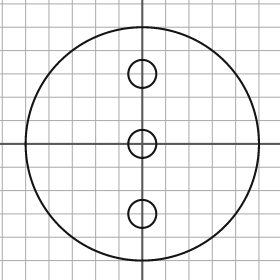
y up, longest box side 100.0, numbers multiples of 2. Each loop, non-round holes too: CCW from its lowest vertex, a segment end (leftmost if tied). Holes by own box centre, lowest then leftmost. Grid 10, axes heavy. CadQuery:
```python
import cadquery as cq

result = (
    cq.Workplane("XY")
    .moveTo(0.0, 0.0)
    .circle(50.0)
    .moveTo(0.0, -30.0)
    .circle(6.0)
    .moveTo(0.0, 0.0)
    .circle(6.0)
    .moveTo(0.0, 30.0)
    .circle(6.0)
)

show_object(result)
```